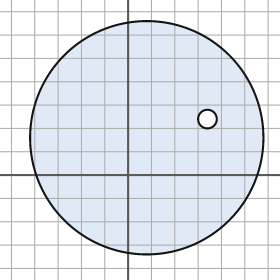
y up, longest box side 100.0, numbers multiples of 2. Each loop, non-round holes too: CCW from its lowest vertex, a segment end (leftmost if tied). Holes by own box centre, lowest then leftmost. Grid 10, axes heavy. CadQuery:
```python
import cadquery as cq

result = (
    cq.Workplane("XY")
    .moveTo(8.0, 16.0)
    .circle(50.0)
    .moveTo(34.0, 24.0)
    .circle(4.0)
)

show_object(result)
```